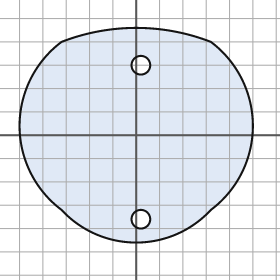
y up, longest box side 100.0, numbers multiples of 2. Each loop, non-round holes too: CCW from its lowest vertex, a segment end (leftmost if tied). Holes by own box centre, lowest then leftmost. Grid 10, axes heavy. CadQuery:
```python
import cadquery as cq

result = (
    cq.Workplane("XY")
    .moveTo(-32.0, -32.0)
    .threePointArc((0.0, -46.0), (32.0, -32.0))
    .threePointArc((50.0, 4.0), (32.0, 40.0))
    .threePointArc((0.0, 46.0), (-32.0, 40.0))
    .threePointArc((-50.0, 4.0), (-32.0, -32.0))
    .close()
    .moveTo(2.0, -36.0)
    .circle(4.0)
    .moveTo(2.0, 30.0)
    .circle(4.0)
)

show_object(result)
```